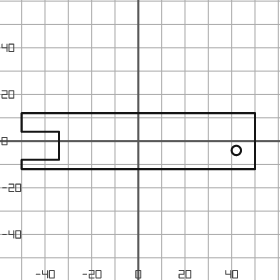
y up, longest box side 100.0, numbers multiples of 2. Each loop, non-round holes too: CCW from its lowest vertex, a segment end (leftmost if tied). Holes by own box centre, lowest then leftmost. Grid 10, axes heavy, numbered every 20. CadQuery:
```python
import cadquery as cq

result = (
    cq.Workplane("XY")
    .moveTo(-50.0, -12.0)
    .lineTo(50.0, -12.0)
    .lineTo(50.0, 12.0)
    .lineTo(-50.0, 12.0)
    .lineTo(-50.0, 4.0)
    .lineTo(-34.0, 4.0)
    .lineTo(-34.0, -8.0)
    .lineTo(-50.0, -8.0)
    .close()
    .moveTo(42.0, -4.0)
    .circle(2.0)
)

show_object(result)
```